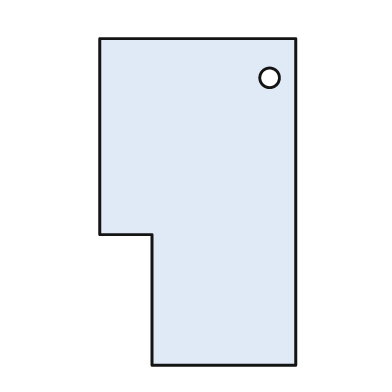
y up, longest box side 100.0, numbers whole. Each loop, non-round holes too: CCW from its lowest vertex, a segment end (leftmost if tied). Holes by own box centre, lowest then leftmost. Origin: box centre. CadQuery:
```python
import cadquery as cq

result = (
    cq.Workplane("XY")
    .moveTo(-14.0, -50.0)
    .lineTo(30.0, -50.0)
    .lineTo(30.0, 50.0)
    .lineTo(-30.0, 50.0)
    .lineTo(-30.0, -10.0)
    .lineTo(-14.0, -10.0)
    .close()
    .moveTo(22.0, 38.0)
    .circle(3.0)
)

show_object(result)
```